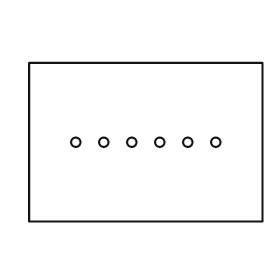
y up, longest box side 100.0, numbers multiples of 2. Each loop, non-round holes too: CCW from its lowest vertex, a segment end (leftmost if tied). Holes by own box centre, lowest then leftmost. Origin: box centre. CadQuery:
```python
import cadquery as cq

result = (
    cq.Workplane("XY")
    .moveTo(-50.0, -34.0)
    .lineTo(50.0, -34.0)
    .lineTo(50.0, 34.0)
    .lineTo(-50.0, 34.0)
    .close()
    .moveTo(-30.0, 0.0)
    .circle(2.0)
    .moveTo(-18.0, 0.0)
    .circle(2.0)
    .moveTo(-6.0, 0.0)
    .circle(2.0)
    .moveTo(6.0, 0.0)
    .circle(2.0)
    .moveTo(18.0, 0.0)
    .circle(2.0)
    .moveTo(30.0, 0.0)
    .circle(2.0)
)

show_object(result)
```